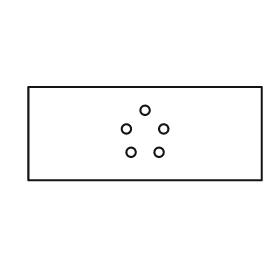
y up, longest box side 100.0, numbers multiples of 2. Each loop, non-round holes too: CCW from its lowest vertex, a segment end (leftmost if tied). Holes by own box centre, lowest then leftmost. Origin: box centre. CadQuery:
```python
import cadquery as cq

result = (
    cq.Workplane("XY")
    .moveTo(-50.0, -20.0)
    .lineTo(50.0, -20.0)
    .lineTo(50.0, 20.0)
    .lineTo(-50.0, 20.0)
    .close()
    .moveTo(-6.0, -8.0)
    .circle(2.0)
    .moveTo(6.0, -8.0)
    .circle(2.0)
    .moveTo(-8.0, 2.0)
    .circle(2.0)
    .moveTo(8.0, 2.0)
    .circle(2.0)
    .moveTo(0.0, 10.0)
    .circle(2.0)
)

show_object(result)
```